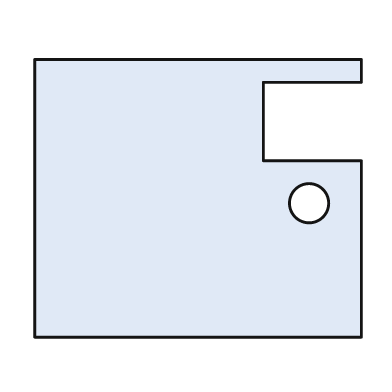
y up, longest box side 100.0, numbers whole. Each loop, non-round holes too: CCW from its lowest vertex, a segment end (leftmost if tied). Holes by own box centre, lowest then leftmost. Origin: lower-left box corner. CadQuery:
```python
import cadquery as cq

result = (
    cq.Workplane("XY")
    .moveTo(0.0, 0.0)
    .lineTo(100.0, 0.0)
    .lineTo(100.0, 54.0)
    .lineTo(70.0, 54.0)
    .lineTo(70.0, 78.0)
    .lineTo(100.0, 78.0)
    .lineTo(100.0, 85.0)
    .lineTo(0.0, 85.0)
    .close()
    .moveTo(84.0, 41.0)
    .circle(6.0)
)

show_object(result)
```